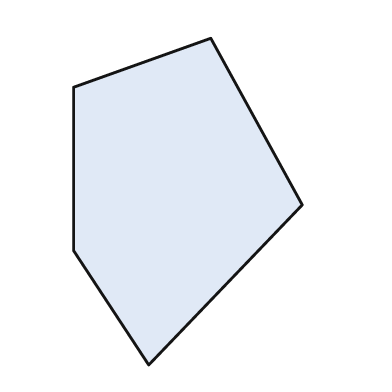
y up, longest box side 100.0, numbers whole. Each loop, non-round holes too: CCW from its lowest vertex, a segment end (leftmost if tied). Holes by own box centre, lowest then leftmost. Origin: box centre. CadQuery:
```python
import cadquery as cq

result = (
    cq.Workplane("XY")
    .moveTo(-12.0, -50.0)
    .lineTo(35.0, -1.0)
    .lineTo(7.0, 50.0)
    .lineTo(-35.0, 35.0)
    .lineTo(-35.0, -15.0)
    .close()
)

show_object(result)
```